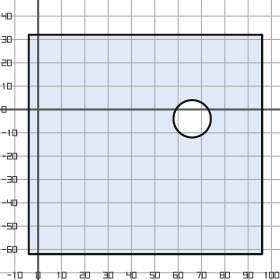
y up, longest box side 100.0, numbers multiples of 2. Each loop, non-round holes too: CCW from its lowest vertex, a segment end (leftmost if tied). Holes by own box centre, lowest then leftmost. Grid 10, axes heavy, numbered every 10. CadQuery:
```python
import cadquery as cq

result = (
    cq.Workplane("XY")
    .moveTo(-4.0, -62.0)
    .lineTo(96.0, -62.0)
    .lineTo(96.0, 32.0)
    .lineTo(-4.0, 32.0)
    .close()
    .moveTo(66.0, -4.0)
    .circle(8.0)
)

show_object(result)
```